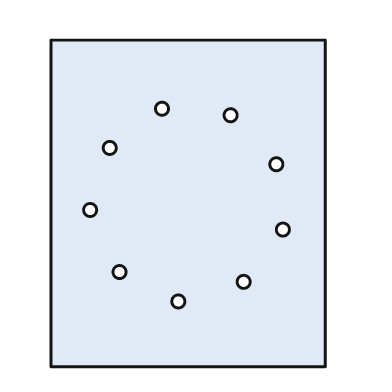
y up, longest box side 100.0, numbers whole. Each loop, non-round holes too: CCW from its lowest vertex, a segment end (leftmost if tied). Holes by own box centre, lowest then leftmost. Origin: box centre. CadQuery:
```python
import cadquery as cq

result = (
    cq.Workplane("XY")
    .moveTo(-42.0, -50.0)
    .lineTo(42.0, -50.0)
    .lineTo(42.0, 50.0)
    .lineTo(-42.0, 50.0)
    .close()
    .moveTo(-3.0, -30.0)
    .circle(2.0)
    .moveTo(17.0, -24.0)
    .circle(2.0)
    .moveTo(-21.0, -21.0)
    .circle(2.0)
    .moveTo(29.0, -8.0)
    .circle(2.0)
    .moveTo(-30.0, -2.0)
    .circle(2.0)
    .moveTo(27.0, 12.0)
    .circle(2.0)
    .moveTo(-24.0, 17.0)
    .circle(2.0)
    .moveTo(13.0, 27.0)
    .circle(2.0)
    .moveTo(-8.0, 29.0)
    .circle(2.0)
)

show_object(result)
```